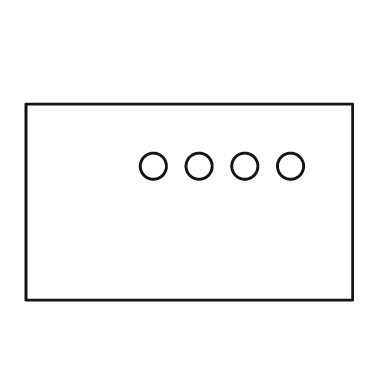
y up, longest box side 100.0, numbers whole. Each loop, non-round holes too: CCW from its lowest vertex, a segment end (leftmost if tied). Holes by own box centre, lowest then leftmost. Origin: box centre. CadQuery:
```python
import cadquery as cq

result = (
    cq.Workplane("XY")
    .moveTo(-50.0, -30.0)
    .lineTo(50.0, -30.0)
    .lineTo(50.0, 30.0)
    .lineTo(-50.0, 30.0)
    .close()
    .moveTo(-11.0, 11.0)
    .circle(4.0)
    .moveTo(3.0, 11.0)
    .circle(4.0)
    .moveTo(17.0, 11.0)
    .circle(4.0)
    .moveTo(31.0, 11.0)
    .circle(4.0)
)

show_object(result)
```